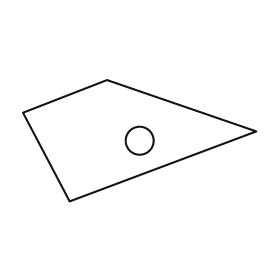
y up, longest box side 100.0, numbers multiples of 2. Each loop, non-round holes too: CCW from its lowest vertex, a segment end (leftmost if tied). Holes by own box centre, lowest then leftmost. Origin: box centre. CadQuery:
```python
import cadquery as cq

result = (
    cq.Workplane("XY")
    .moveTo(-30.0, -26.0)
    .lineTo(50.0, 4.0)
    .lineTo(-14.0, 26.0)
    .lineTo(-50.0, 12.0)
    .close()
    .moveTo(0.0, 0.0)
    .circle(6.0)
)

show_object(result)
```